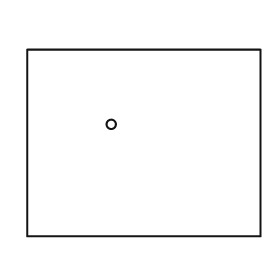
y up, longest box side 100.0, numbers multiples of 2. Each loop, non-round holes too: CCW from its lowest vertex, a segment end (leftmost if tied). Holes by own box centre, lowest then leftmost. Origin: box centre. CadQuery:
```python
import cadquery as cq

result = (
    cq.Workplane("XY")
    .moveTo(-50.0, -40.0)
    .lineTo(50.0, -40.0)
    .lineTo(50.0, 40.0)
    .lineTo(-50.0, 40.0)
    .close()
    .moveTo(-14.0, 8.0)
    .circle(2.0)
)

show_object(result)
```